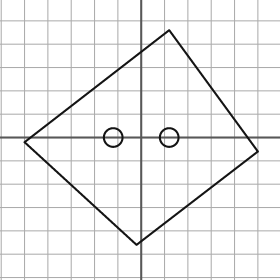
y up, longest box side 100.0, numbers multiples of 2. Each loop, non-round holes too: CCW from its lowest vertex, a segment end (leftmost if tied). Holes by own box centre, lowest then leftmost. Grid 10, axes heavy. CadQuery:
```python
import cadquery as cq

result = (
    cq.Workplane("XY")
    .moveTo(-2.0, -46.0)
    .lineTo(50.0, -6.0)
    .lineTo(12.0, 46.0)
    .lineTo(-50.0, -2.0)
    .close()
    .moveTo(-12.0, 0.0)
    .circle(4.0)
    .moveTo(12.0, 0.0)
    .circle(4.0)
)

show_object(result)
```